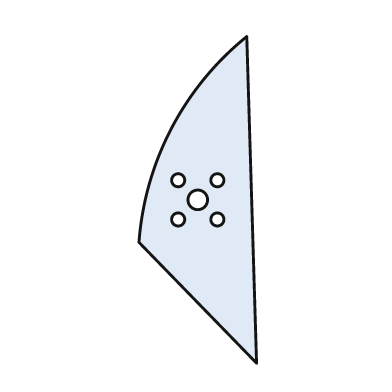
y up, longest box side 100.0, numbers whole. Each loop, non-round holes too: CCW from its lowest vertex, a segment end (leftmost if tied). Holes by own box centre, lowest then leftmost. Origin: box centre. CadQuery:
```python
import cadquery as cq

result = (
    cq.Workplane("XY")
    .moveTo(18.0, -50.0)
    .lineTo(15.0, 50.0)
    .threePointArc((-8.0, 22.0), (-18.0, -13.0))
    .close()
    .moveTo(-6.0, -6.0)
    .circle(2.0)
    .moveTo(6.0, -6.0)
    .circle(2.0)
    .moveTo(0.0, 0.0)
    .circle(3.0)
    .moveTo(-6.0, 6.0)
    .circle(2.0)
    .moveTo(6.0, 6.0)
    .circle(2.0)
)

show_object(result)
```